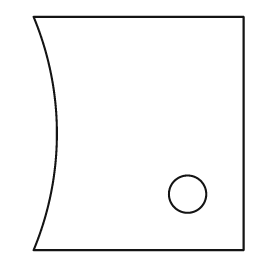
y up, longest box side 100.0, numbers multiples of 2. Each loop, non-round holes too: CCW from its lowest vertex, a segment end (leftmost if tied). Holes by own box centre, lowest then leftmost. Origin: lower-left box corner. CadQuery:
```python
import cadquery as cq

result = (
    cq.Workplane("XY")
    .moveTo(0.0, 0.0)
    .lineTo(90.0, 0.0)
    .lineTo(90.0, 100.0)
    .lineTo(0.0, 100.0)
    .threePointArc((10.0, 50.0), (0.0, 0.0))
    .close()
    .moveTo(66.0, 24.0)
    .circle(8.0)
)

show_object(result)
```